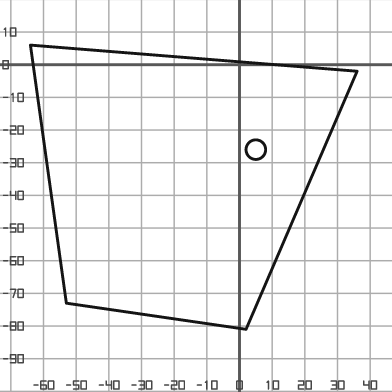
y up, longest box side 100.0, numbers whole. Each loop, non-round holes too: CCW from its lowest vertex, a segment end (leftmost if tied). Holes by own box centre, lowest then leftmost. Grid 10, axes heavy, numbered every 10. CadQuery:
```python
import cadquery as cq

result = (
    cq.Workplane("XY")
    .moveTo(2.0, -81.0)
    .lineTo(36.0, -2.0)
    .lineTo(-64.0, 6.0)
    .lineTo(-53.0, -73.0)
    .close()
    .moveTo(5.0, -26.0)
    .circle(3.0)
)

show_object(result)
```